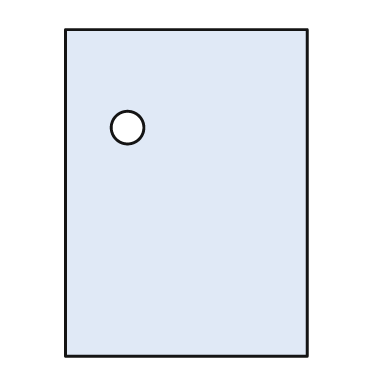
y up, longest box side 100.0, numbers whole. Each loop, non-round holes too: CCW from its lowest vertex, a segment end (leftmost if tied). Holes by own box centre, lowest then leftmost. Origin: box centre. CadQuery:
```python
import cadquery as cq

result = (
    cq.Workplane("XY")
    .moveTo(-37.0, -50.0)
    .lineTo(37.0, -50.0)
    .lineTo(37.0, 50.0)
    .lineTo(-37.0, 50.0)
    .close()
    .moveTo(-18.0, 20.0)
    .circle(5.0)
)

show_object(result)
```